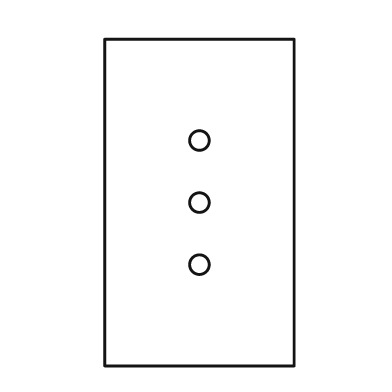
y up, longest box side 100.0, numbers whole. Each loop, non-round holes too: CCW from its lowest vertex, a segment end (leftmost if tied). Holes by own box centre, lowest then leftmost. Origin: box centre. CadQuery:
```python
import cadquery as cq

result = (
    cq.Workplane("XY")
    .moveTo(-29.0, -50.0)
    .lineTo(29.0, -50.0)
    .lineTo(29.0, 50.0)
    .lineTo(-29.0, 50.0)
    .close()
    .moveTo(0.0, -19.0)
    .circle(3.0)
    .moveTo(0.0, 0.0)
    .circle(3.0)
    .moveTo(0.0, 19.0)
    .circle(3.0)
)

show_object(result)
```